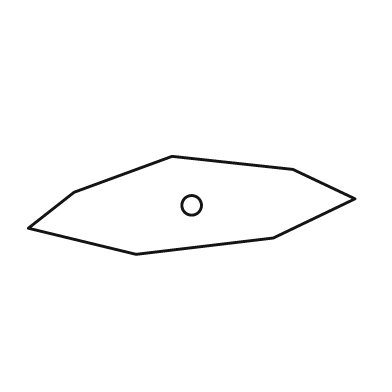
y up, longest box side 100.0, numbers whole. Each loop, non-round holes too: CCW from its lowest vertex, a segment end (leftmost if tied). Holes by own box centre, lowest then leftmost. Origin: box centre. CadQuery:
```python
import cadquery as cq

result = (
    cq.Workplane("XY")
    .moveTo(-17.0, -15.0)
    .lineTo(25.0, -10.0)
    .lineTo(50.0, 2.0)
    .lineTo(31.0, 11.0)
    .lineTo(-6.0, 15.0)
    .lineTo(-36.0, 4.0)
    .lineTo(-50.0, -7.0)
    .close()
    .moveTo(0.0, 0.0)
    .circle(3.0)
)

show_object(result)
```